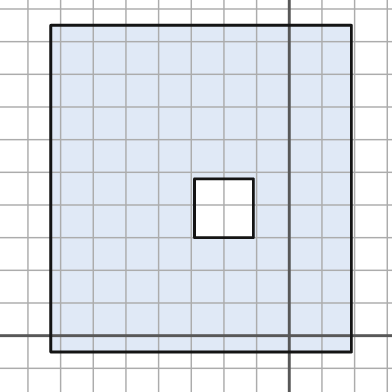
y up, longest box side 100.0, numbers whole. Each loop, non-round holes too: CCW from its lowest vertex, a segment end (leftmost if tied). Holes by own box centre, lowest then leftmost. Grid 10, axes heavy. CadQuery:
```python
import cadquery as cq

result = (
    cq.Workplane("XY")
    .moveTo(-73.0, -5.0)
    .lineTo(19.0, -5.0)
    .lineTo(19.0, 95.0)
    .lineTo(-73.0, 95.0)
    .close()
    .moveTo(-29.0, 30.0)
    .lineTo(-11.0, 30.0)
    .lineTo(-11.0, 48.0)
    .lineTo(-29.0, 48.0)
    .close()
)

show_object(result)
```